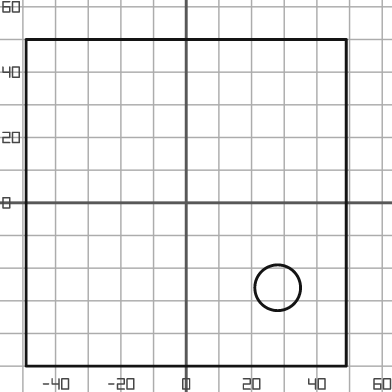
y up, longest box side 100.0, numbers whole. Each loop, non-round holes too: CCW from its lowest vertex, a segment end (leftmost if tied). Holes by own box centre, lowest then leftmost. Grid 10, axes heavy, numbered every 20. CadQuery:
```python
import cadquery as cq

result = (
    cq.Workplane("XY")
    .moveTo(-49.0, -50.0)
    .lineTo(49.0, -50.0)
    .lineTo(49.0, 50.0)
    .lineTo(-49.0, 50.0)
    .close()
    .moveTo(28.0, -26.0)
    .circle(7.0)
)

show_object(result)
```